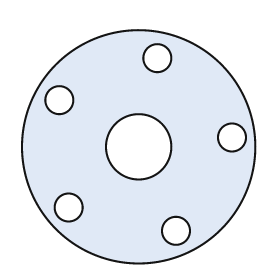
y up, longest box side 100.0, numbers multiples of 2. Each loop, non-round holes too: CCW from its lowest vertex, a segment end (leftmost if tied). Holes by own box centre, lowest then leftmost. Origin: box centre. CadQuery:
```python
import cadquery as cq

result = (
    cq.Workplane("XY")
    .moveTo(0.0, 0.0)
    .circle(50.0)
    .moveTo(16.0, -36.0)
    .circle(6.0)
    .moveTo(-30.0, -26.0)
    .circle(6.0)
    .moveTo(0.0, 0.0)
    .circle(14.0)
    .moveTo(40.0, 4.0)
    .circle(6.0)
    .moveTo(-34.0, 20.0)
    .circle(6.0)
    .moveTo(8.0, 38.0)
    .circle(6.0)
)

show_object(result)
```